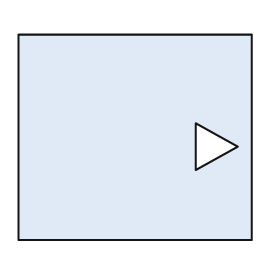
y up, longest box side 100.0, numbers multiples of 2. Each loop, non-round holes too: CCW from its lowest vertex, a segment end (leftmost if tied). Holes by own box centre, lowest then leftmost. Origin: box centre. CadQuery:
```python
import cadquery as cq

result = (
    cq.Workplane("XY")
    .moveTo(-50.0, -44.0)
    .lineTo(50.0, -44.0)
    .lineTo(50.0, 44.0)
    .lineTo(-50.0, 44.0)
    .close()
    .moveTo(26.0, -14.0)
    .lineTo(44.0, -4.0)
    .lineTo(26.0, 6.0)
    .close()
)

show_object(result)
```